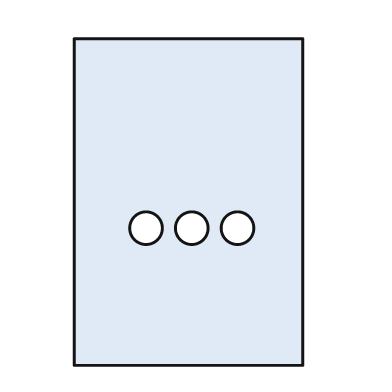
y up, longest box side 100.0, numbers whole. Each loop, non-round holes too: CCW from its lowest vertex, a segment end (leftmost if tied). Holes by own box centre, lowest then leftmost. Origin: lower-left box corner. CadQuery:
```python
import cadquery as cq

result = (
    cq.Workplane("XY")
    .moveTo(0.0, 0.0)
    .lineTo(70.0, 0.0)
    .lineTo(70.0, 100.0)
    .lineTo(0.0, 100.0)
    .close()
    .moveTo(22.0, 42.0)
    .circle(5.0)
    .moveTo(36.0, 42.0)
    .circle(5.0)
    .moveTo(50.0, 42.0)
    .circle(5.0)
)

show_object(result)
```